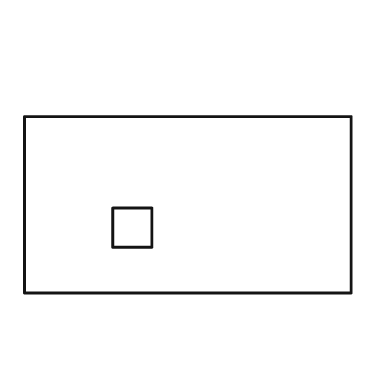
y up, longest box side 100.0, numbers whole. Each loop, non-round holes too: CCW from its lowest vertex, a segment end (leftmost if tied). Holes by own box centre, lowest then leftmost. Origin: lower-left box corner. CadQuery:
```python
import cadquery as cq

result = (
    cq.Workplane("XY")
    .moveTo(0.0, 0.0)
    .lineTo(100.0, 0.0)
    .lineTo(100.0, 54.0)
    .lineTo(0.0, 54.0)
    .close()
    .moveTo(27.0, 14.0)
    .lineTo(39.0, 14.0)
    .lineTo(39.0, 26.0)
    .lineTo(27.0, 26.0)
    .close()
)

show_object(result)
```